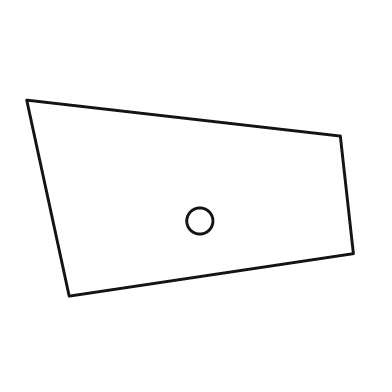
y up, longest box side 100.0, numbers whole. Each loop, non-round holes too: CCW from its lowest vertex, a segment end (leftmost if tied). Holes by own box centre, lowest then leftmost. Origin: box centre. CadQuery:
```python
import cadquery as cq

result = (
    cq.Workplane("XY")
    .moveTo(-37.0, -30.0)
    .lineTo(50.0, -17.0)
    .lineTo(46.0, 19.0)
    .lineTo(-50.0, 30.0)
    .close()
    .moveTo(3.0, -7.0)
    .circle(4.0)
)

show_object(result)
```